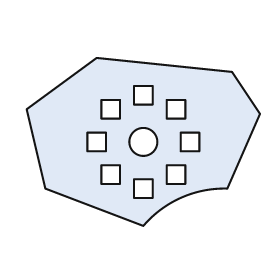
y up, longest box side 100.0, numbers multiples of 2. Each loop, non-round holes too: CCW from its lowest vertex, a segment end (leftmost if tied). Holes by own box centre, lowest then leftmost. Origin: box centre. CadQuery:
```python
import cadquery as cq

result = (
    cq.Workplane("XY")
    .moveTo(0.0, -36.0)
    .threePointArc((16.0, -24.0), (36.0, -20.0))
    .lineTo(50.0, 12.0)
    .lineTo(38.0, 30.0)
    .lineTo(-20.0, 36.0)
    .lineTo(-50.0, 14.0)
    .lineTo(-42.0, -20.0)
    .close()
    .moveTo(-4.0, -24.0)
    .lineTo(4.0, -24.0)
    .lineTo(4.0, -16.0)
    .lineTo(-4.0, -16.0)
    .close()
    .moveTo(-18.0, -18.0)
    .lineTo(-10.0, -18.0)
    .lineTo(-10.0, -10.0)
    .lineTo(-18.0, -10.0)
    .close()
    .moveTo(10.0, -18.0)
    .lineTo(18.0, -18.0)
    .lineTo(18.0, -10.0)
    .lineTo(10.0, -10.0)
    .close()
    .moveTo(-24.0, -4.0)
    .lineTo(-16.0, -4.0)
    .lineTo(-16.0, 4.0)
    .lineTo(-24.0, 4.0)
    .close()
    .moveTo(0.0, 0.0)
    .circle(6.0)
    .moveTo(16.0, -4.0)
    .lineTo(24.0, -4.0)
    .lineTo(24.0, 4.0)
    .lineTo(16.0, 4.0)
    .close()
    .moveTo(-18.0, 10.0)
    .lineTo(-10.0, 10.0)
    .lineTo(-10.0, 18.0)
    .lineTo(-18.0, 18.0)
    .close()
    .moveTo(10.0, 10.0)
    .lineTo(18.0, 10.0)
    .lineTo(18.0, 18.0)
    .lineTo(10.0, 18.0)
    .close()
    .moveTo(-4.0, 16.0)
    .lineTo(4.0, 16.0)
    .lineTo(4.0, 24.0)
    .lineTo(-4.0, 24.0)
    .close()
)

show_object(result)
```